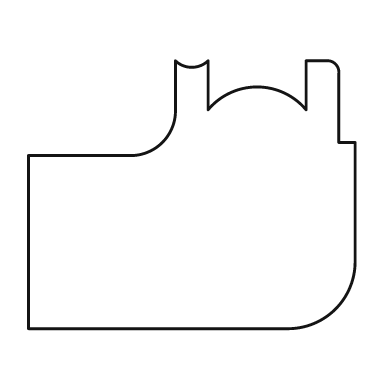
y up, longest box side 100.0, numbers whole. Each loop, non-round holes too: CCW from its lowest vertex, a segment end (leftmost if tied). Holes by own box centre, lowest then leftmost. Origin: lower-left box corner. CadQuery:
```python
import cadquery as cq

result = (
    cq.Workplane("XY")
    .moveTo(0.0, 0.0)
    .lineTo(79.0, 0.0)
    .threePointArc((94.0, 6.0), (100.0, 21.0))
    .lineTo(100.0, 57.0)
    .lineTo(95.0, 57.0)
    .lineTo(95.0, 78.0)
    .threePointArc((94.0, 81.0), (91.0, 82.0))
    .lineTo(85.0, 82.0)
    .lineTo(85.0, 67.0)
    .threePointArc((70.0, 74.0), (55.0, 67.0))
    .lineTo(55.0, 82.0)
    .threePointArc((50.0, 80.0), (45.0, 82.0))
    .lineTo(45.0, 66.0)
    .threePointArc((41.0, 57.0), (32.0, 53.0))
    .lineTo(0.0, 53.0)
    .close()
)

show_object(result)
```